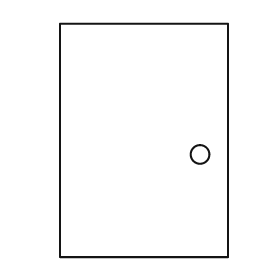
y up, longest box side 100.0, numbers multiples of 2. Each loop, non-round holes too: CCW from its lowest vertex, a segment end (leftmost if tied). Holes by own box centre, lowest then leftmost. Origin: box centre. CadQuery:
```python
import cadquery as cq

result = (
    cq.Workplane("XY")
    .moveTo(-36.0, -50.0)
    .lineTo(36.0, -50.0)
    .lineTo(36.0, 50.0)
    .lineTo(-36.0, 50.0)
    .close()
    .moveTo(24.0, -6.0)
    .circle(4.0)
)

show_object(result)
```